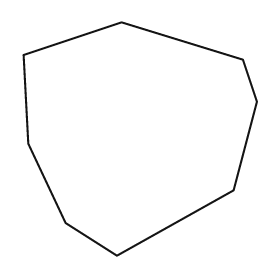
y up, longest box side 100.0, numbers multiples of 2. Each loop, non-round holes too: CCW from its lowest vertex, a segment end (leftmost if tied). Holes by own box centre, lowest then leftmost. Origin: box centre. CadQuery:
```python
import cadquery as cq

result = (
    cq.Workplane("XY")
    .moveTo(-10.0, -50.0)
    .lineTo(40.0, -22.0)
    .lineTo(50.0, 16.0)
    .lineTo(44.0, 34.0)
    .lineTo(-8.0, 50.0)
    .lineTo(-50.0, 36.0)
    .lineTo(-48.0, -2.0)
    .lineTo(-32.0, -36.0)
    .close()
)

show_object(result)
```